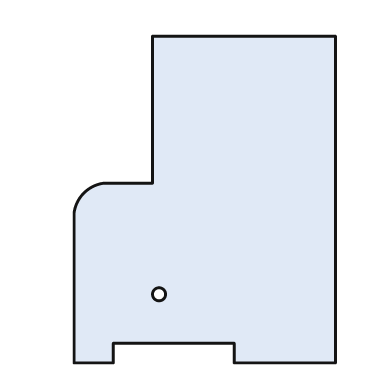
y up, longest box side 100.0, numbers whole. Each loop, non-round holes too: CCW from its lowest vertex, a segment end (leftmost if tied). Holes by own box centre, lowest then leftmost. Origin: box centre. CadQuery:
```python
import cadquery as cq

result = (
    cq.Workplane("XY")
    .moveTo(-40.0, -50.0)
    .lineTo(-28.0, -50.0)
    .lineTo(-28.0, -44.0)
    .lineTo(9.0, -44.0)
    .lineTo(9.0, -50.0)
    .lineTo(40.0, -50.0)
    .lineTo(40.0, 50.0)
    .lineTo(-16.0, 50.0)
    .lineTo(-16.0, 5.0)
    .lineTo(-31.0, 5.0)
    .threePointArc((-37.0, 2.0), (-40.0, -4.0))
    .close()
    .moveTo(-14.0, -29.0)
    .circle(2.0)
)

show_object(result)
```